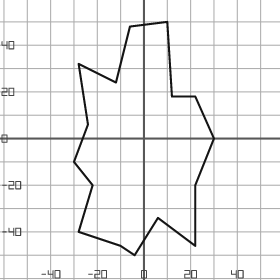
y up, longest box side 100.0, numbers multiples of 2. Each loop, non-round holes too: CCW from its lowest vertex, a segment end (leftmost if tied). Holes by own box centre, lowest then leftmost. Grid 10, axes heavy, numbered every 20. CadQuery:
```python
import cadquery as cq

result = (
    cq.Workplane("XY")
    .moveTo(-4.0, -50.0)
    .lineTo(6.0, -34.0)
    .lineTo(22.0, -46.0)
    .lineTo(22.0, -20.0)
    .lineTo(30.0, 0.0)
    .lineTo(22.0, 18.0)
    .lineTo(12.0, 18.0)
    .lineTo(10.0, 50.0)
    .lineTo(-6.0, 48.0)
    .lineTo(-12.0, 24.0)
    .lineTo(-28.0, 32.0)
    .lineTo(-24.0, 6.0)
    .lineTo(-30.0, -10.0)
    .lineTo(-22.0, -20.0)
    .lineTo(-28.0, -40.0)
    .lineTo(-10.0, -46.0)
    .close()
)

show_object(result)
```